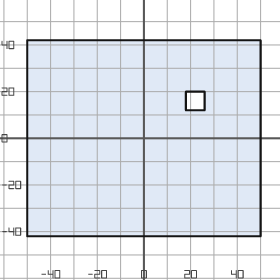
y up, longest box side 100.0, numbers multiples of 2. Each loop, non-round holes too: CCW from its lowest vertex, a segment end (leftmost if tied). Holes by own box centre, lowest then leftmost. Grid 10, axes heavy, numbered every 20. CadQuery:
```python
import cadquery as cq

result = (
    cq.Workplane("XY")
    .moveTo(-50.0, -42.0)
    .lineTo(50.0, -42.0)
    .lineTo(50.0, 42.0)
    .lineTo(-50.0, 42.0)
    .close()
    .moveTo(18.0, 12.0)
    .lineTo(26.0, 12.0)
    .lineTo(26.0, 20.0)
    .lineTo(18.0, 20.0)
    .close()
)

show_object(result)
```